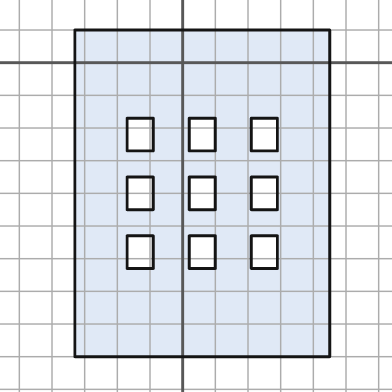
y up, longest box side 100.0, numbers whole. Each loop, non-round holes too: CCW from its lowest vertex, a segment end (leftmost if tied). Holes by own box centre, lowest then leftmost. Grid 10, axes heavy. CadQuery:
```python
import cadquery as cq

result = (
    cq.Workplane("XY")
    .moveTo(-33.0, -90.0)
    .lineTo(45.0, -90.0)
    .lineTo(45.0, 10.0)
    .lineTo(-33.0, 10.0)
    .close()
    .moveTo(-17.0, -63.0)
    .lineTo(-9.0, -63.0)
    .lineTo(-9.0, -53.0)
    .lineTo(-17.0, -53.0)
    .close()
    .moveTo(2.0, -63.0)
    .lineTo(10.0, -63.0)
    .lineTo(10.0, -53.0)
    .lineTo(2.0, -53.0)
    .close()
    .moveTo(21.0, -63.0)
    .lineTo(29.0, -63.0)
    .lineTo(29.0, -53.0)
    .lineTo(21.0, -53.0)
    .close()
    .moveTo(-17.0, -45.0)
    .lineTo(-9.0, -45.0)
    .lineTo(-9.0, -35.0)
    .lineTo(-17.0, -35.0)
    .close()
    .moveTo(2.0, -45.0)
    .lineTo(10.0, -45.0)
    .lineTo(10.0, -35.0)
    .lineTo(2.0, -35.0)
    .close()
    .moveTo(21.0, -45.0)
    .lineTo(29.0, -45.0)
    .lineTo(29.0, -35.0)
    .lineTo(21.0, -35.0)
    .close()
    .moveTo(-17.0, -27.0)
    .lineTo(-9.0, -27.0)
    .lineTo(-9.0, -17.0)
    .lineTo(-17.0, -17.0)
    .close()
    .moveTo(2.0, -27.0)
    .lineTo(10.0, -27.0)
    .lineTo(10.0, -17.0)
    .lineTo(2.0, -17.0)
    .close()
    .moveTo(21.0, -27.0)
    .lineTo(29.0, -27.0)
    .lineTo(29.0, -17.0)
    .lineTo(21.0, -17.0)
    .close()
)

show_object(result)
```